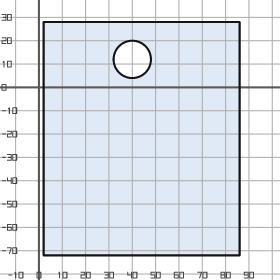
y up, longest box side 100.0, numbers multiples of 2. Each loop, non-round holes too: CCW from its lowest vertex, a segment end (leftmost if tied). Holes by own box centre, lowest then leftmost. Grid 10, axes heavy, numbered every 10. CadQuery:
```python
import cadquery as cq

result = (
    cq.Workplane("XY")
    .moveTo(2.0, -72.0)
    .lineTo(86.0, -72.0)
    .lineTo(86.0, 28.0)
    .lineTo(2.0, 28.0)
    .close()
    .moveTo(40.0, 12.0)
    .circle(8.0)
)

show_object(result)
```